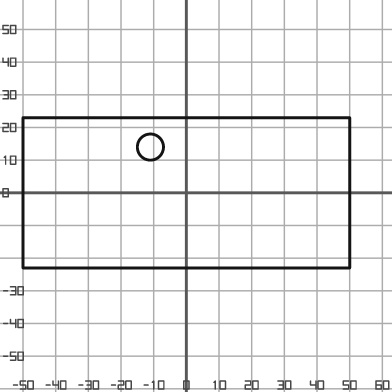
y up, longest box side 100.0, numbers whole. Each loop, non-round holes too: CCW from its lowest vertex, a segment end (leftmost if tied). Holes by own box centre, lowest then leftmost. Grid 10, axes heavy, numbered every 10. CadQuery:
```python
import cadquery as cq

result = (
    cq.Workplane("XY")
    .moveTo(-50.0, -23.0)
    .lineTo(50.0, -23.0)
    .lineTo(50.0, 23.0)
    .lineTo(-50.0, 23.0)
    .close()
    .moveTo(-11.0, 14.0)
    .circle(4.0)
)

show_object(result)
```